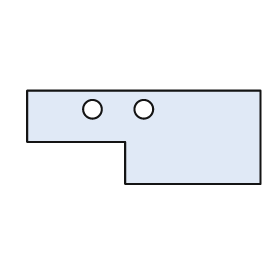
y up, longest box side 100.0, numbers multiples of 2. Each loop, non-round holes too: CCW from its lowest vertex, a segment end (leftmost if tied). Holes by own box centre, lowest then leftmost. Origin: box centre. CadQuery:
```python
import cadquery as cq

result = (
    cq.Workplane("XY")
    .moveTo(-8.0, -20.0)
    .lineTo(50.0, -20.0)
    .lineTo(50.0, 20.0)
    .lineTo(-50.0, 20.0)
    .lineTo(-50.0, -2.0)
    .lineTo(-8.0, -2.0)
    .close()
    .moveTo(-22.0, 12.0)
    .circle(4.0)
    .moveTo(0.0, 12.0)
    .circle(4.0)
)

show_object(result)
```